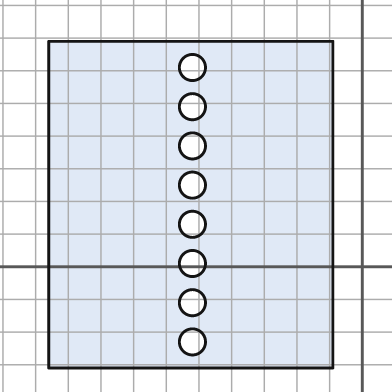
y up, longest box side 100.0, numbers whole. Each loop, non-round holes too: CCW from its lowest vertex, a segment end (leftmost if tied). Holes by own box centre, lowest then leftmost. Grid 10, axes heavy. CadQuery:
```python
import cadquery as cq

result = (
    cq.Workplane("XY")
    .moveTo(-96.0, -31.0)
    .lineTo(-9.0, -31.0)
    .lineTo(-9.0, 69.0)
    .lineTo(-96.0, 69.0)
    .close()
    .moveTo(-52.0, -23.0)
    .circle(4.0)
    .moveTo(-52.0, -11.0)
    .circle(4.0)
    .moveTo(-52.0, 1.0)
    .circle(4.0)
    .moveTo(-52.0, 13.0)
    .circle(4.0)
    .moveTo(-52.0, 25.0)
    .circle(4.0)
    .moveTo(-52.0, 37.0)
    .circle(4.0)
    .moveTo(-52.0, 49.0)
    .circle(4.0)
    .moveTo(-52.0, 61.0)
    .circle(4.0)
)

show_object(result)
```